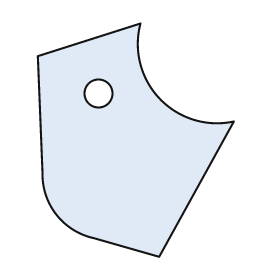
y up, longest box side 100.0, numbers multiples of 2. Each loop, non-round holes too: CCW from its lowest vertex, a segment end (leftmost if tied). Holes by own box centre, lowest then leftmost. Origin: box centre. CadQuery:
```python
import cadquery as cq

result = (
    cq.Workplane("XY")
    .moveTo(10.0, -50.0)
    .lineTo(42.0, 8.0)
    .threePointArc((10.0, 18.0), (2.0, 50.0))
    .lineTo(-42.0, 36.0)
    .lineTo(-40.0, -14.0)
    .threePointArc((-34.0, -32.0), (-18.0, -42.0))
    .close()
    .moveTo(-16.0, 20.0)
    .circle(6.0)
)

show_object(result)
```